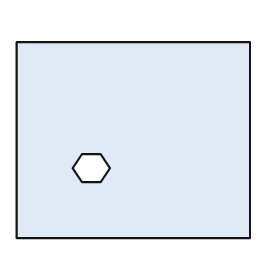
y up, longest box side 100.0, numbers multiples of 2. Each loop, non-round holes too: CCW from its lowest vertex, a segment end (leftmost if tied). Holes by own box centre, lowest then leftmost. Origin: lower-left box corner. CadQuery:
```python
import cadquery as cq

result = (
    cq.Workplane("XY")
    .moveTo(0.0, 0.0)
    .lineTo(100.0, 0.0)
    .lineTo(100.0, 84.0)
    .lineTo(0.0, 84.0)
    .close()
    .moveTo(28.0, 24.0)
    .lineTo(36.0, 24.0)
    .lineTo(40.0, 30.0)
    .lineTo(36.0, 36.0)
    .lineTo(28.0, 36.0)
    .lineTo(24.0, 30.0)
    .close()
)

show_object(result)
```